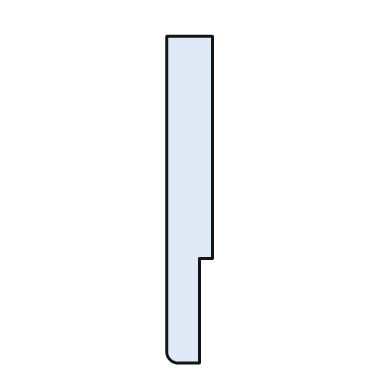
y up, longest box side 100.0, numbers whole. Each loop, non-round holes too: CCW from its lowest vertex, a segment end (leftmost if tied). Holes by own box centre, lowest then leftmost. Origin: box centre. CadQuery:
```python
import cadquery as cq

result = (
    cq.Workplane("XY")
    .moveTo(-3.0, -50.0)
    .lineTo(3.0, -50.0)
    .lineTo(3.0, -18.0)
    .lineTo(7.0, -18.0)
    .lineTo(7.0, 50.0)
    .lineTo(-7.0, 50.0)
    .lineTo(-7.0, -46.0)
    .threePointArc((-6.0, -49.0), (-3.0, -50.0))
    .close()
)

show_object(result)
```